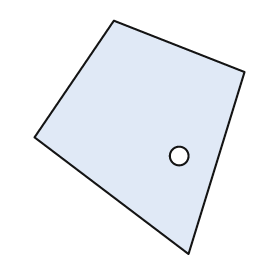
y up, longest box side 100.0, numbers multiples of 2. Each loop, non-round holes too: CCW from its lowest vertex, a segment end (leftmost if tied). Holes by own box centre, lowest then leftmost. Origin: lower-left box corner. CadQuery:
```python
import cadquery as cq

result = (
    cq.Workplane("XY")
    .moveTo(66.0, 0.0)
    .lineTo(90.0, 78.0)
    .lineTo(34.0, 100.0)
    .lineTo(0.0, 50.0)
    .close()
    .moveTo(62.0, 42.0)
    .circle(4.0)
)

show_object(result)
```